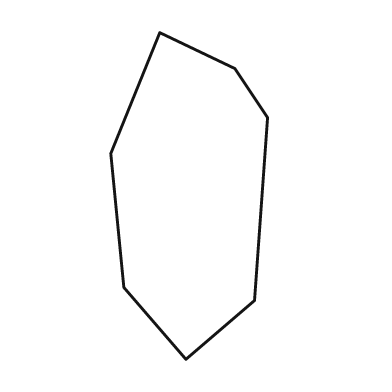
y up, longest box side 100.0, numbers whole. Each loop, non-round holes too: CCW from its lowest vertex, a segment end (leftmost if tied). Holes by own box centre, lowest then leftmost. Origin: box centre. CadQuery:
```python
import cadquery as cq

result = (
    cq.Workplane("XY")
    .moveTo(-1.0, -50.0)
    .lineTo(20.0, -32.0)
    .lineTo(24.0, 24.0)
    .lineTo(14.0, 39.0)
    .lineTo(-9.0, 50.0)
    .lineTo(-24.0, 13.0)
    .lineTo(-20.0, -28.0)
    .close()
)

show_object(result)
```